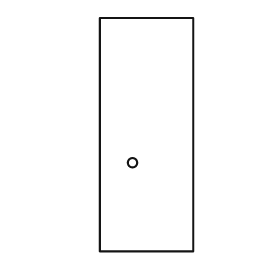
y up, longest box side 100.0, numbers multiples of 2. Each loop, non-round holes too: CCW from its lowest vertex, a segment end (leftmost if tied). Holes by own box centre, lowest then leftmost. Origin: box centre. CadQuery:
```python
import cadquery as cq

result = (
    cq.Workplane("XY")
    .moveTo(-20.0, -50.0)
    .lineTo(20.0, -50.0)
    .lineTo(20.0, 50.0)
    .lineTo(-20.0, 50.0)
    .close()
    .moveTo(-6.0, -12.0)
    .circle(2.0)
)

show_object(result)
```